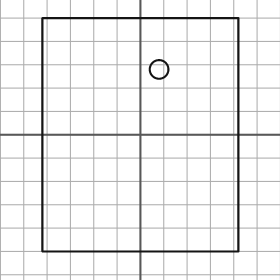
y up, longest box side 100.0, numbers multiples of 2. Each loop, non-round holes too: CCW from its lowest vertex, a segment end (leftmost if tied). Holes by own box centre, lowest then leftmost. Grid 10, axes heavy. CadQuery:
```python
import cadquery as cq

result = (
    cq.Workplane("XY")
    .moveTo(-42.0, -50.0)
    .lineTo(42.0, -50.0)
    .lineTo(42.0, 50.0)
    .lineTo(-42.0, 50.0)
    .close()
    .moveTo(8.0, 28.0)
    .circle(4.0)
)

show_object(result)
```